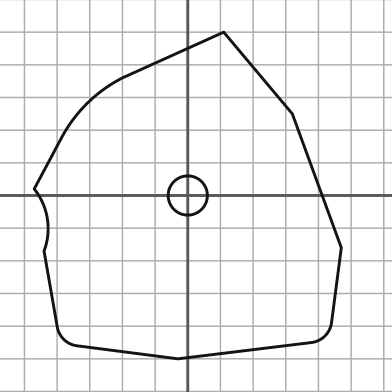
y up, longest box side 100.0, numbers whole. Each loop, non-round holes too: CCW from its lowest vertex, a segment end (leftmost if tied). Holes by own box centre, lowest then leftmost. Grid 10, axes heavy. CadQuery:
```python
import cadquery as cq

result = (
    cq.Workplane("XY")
    .moveTo(-3.0, -50.0)
    .lineTo(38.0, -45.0)
    .threePointArc((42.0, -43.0), (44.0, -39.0))
    .lineTo(47.0, -16.0)
    .lineTo(32.0, 25.0)
    .lineTo(11.0, 50.0)
    .lineTo(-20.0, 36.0)
    .threePointArc((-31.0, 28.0), (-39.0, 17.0))
    .lineTo(-47.0, 2.0)
    .threePointArc((-43.0, -7.0), (-44.0, -17.0))
    .lineTo(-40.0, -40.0)
    .threePointArc((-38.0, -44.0), (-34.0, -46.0))
    .close()
    .moveTo(0.0, 0.0)
    .circle(6.0)
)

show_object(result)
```